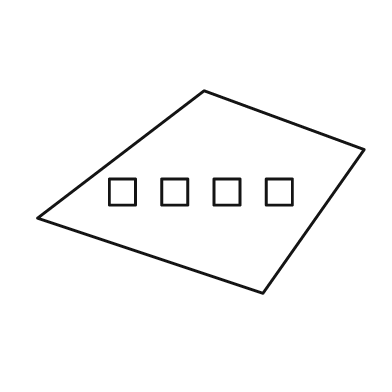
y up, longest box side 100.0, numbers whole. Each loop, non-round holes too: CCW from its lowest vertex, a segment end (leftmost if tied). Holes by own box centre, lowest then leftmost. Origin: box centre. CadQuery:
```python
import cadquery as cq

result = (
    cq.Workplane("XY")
    .moveTo(19.0, -31.0)
    .lineTo(50.0, 13.0)
    .lineTo(1.0, 31.0)
    .lineTo(-50.0, -8.0)
    .close()
    .moveTo(-28.0, -4.0)
    .lineTo(-20.0, -4.0)
    .lineTo(-20.0, 4.0)
    .lineTo(-28.0, 4.0)
    .close()
    .moveTo(-12.0, -4.0)
    .lineTo(-4.0, -4.0)
    .lineTo(-4.0, 4.0)
    .lineTo(-12.0, 4.0)
    .close()
    .moveTo(4.0, -4.0)
    .lineTo(12.0, -4.0)
    .lineTo(12.0, 4.0)
    .lineTo(4.0, 4.0)
    .close()
    .moveTo(20.0, -4.0)
    .lineTo(28.0, -4.0)
    .lineTo(28.0, 4.0)
    .lineTo(20.0, 4.0)
    .close()
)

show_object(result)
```